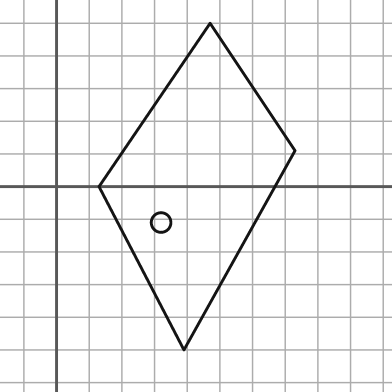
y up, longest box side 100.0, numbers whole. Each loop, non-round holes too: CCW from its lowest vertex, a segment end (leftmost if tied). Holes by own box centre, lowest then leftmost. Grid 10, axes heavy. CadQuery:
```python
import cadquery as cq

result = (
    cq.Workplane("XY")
    .moveTo(39.0, -50.0)
    .lineTo(73.0, 11.0)
    .lineTo(47.0, 50.0)
    .lineTo(13.0, 0.0)
    .close()
    .moveTo(32.0, -11.0)
    .circle(3.0)
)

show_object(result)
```